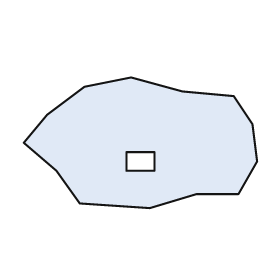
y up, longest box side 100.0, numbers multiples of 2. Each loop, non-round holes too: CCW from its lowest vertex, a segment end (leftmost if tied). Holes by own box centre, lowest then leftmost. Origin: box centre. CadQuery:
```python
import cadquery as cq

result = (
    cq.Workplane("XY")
    .moveTo(4.0, -28.0)
    .lineTo(24.0, -22.0)
    .lineTo(42.0, -22.0)
    .lineTo(50.0, -8.0)
    .lineTo(48.0, 8.0)
    .lineTo(40.0, 20.0)
    .lineTo(18.0, 22.0)
    .lineTo(-4.0, 28.0)
    .lineTo(-24.0, 24.0)
    .lineTo(-40.0, 12.0)
    .lineTo(-50.0, 0.0)
    .lineTo(-36.0, -12.0)
    .lineTo(-26.0, -26.0)
    .close()
    .moveTo(-6.0, -12.0)
    .lineTo(6.0, -12.0)
    .lineTo(6.0, -4.0)
    .lineTo(-6.0, -4.0)
    .close()
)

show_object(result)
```